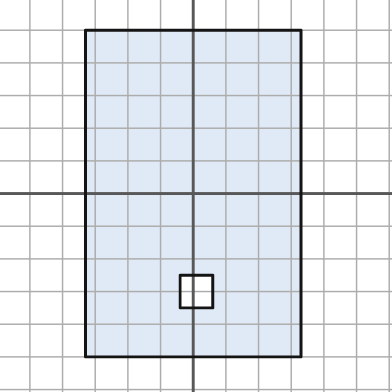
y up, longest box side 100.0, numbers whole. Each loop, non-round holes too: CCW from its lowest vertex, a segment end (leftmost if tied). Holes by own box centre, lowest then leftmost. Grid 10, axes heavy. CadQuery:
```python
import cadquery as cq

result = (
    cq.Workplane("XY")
    .moveTo(-33.0, -50.0)
    .lineTo(33.0, -50.0)
    .lineTo(33.0, 50.0)
    .lineTo(-33.0, 50.0)
    .close()
    .moveTo(-4.0, -35.0)
    .lineTo(6.0, -35.0)
    .lineTo(6.0, -25.0)
    .lineTo(-4.0, -25.0)
    .close()
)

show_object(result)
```